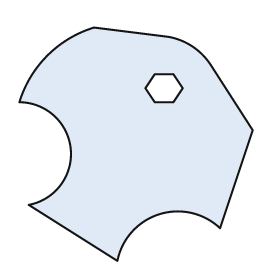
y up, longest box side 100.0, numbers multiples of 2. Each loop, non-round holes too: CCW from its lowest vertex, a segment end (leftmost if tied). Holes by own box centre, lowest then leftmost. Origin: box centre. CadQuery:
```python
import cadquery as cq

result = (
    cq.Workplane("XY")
    .moveTo(-8.0, -50.0)
    .threePointArc((10.0, -30.0), (36.0, -36.0))
    .lineTo(50.0, 6.0)
    .lineTo(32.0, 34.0)
    .threePointArc((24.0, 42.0), (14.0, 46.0))
    .lineTo(-18.0, 50.0)
    .threePointArc((-38.0, 38.0), (-50.0, 18.0))
    .threePointArc((-28.0, -2.0), (-46.0, -26.0))
    .close()
    .moveTo(8.0, 18.0)
    .lineTo(16.0, 18.0)
    .lineTo(20.0, 24.0)
    .lineTo(16.0, 30.0)
    .lineTo(8.0, 30.0)
    .lineTo(4.0, 24.0)
    .close()
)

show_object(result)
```